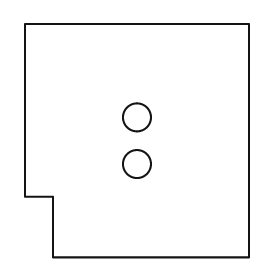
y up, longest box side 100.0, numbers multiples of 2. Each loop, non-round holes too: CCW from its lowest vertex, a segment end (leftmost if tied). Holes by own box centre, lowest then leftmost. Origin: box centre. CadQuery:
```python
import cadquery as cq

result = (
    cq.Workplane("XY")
    .moveTo(-36.0, -50.0)
    .lineTo(48.0, -50.0)
    .lineTo(48.0, 50.0)
    .lineTo(-48.0, 50.0)
    .lineTo(-48.0, -24.0)
    .lineTo(-36.0, -24.0)
    .close()
    .moveTo(0.0, -10.0)
    .circle(6.0)
    .moveTo(0.0, 10.0)
    .circle(6.0)
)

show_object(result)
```